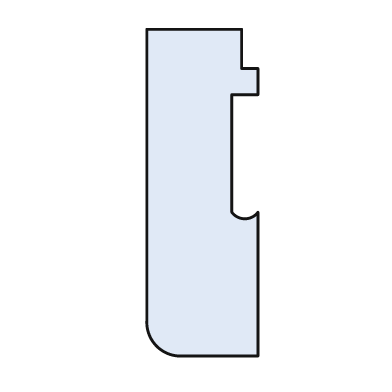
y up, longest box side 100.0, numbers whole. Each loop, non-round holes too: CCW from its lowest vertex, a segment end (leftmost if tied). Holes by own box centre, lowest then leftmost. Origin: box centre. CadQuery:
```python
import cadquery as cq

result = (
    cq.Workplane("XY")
    .moveTo(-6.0, -50.0)
    .lineTo(17.0, -50.0)
    .lineTo(17.0, -6.0)
    .threePointArc((13.0, -8.0), (9.0, -6.0))
    .lineTo(9.0, 30.0)
    .lineTo(17.0, 30.0)
    .lineTo(17.0, 38.0)
    .lineTo(12.0, 38.0)
    .lineTo(12.0, 50.0)
    .lineTo(-17.0, 50.0)
    .lineTo(-17.0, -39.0)
    .threePointArc((-14.0, -47.0), (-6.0, -50.0))
    .close()
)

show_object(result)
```